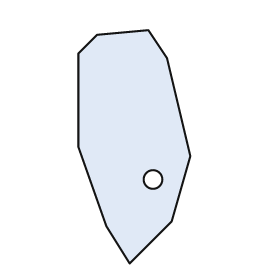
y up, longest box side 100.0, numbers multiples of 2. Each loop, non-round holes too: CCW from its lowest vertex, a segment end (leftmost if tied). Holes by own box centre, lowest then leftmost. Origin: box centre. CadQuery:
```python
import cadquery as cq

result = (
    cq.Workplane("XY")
    .moveTo(-2.0, -50.0)
    .lineTo(16.0, -32.0)
    .lineTo(24.0, -4.0)
    .lineTo(14.0, 38.0)
    .lineTo(6.0, 50.0)
    .lineTo(-16.0, 48.0)
    .lineTo(-24.0, 40.0)
    .lineTo(-24.0, 0.0)
    .lineTo(-12.0, -34.0)
    .close()
    .moveTo(8.0, -14.0)
    .circle(4.0)
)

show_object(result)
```